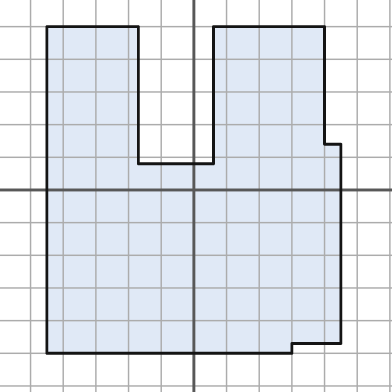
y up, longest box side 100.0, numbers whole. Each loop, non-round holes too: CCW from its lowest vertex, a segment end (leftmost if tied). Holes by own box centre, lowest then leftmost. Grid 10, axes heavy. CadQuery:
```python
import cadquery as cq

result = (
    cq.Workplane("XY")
    .moveTo(-45.0, -50.0)
    .lineTo(30.0, -50.0)
    .lineTo(30.0, -47.0)
    .lineTo(45.0, -47.0)
    .lineTo(45.0, 14.0)
    .lineTo(40.0, 14.0)
    .lineTo(40.0, 50.0)
    .lineTo(6.0, 50.0)
    .lineTo(6.0, 8.0)
    .lineTo(-17.0, 8.0)
    .lineTo(-17.0, 50.0)
    .lineTo(-45.0, 50.0)
    .close()
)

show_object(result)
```